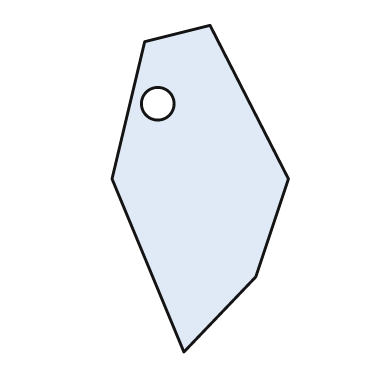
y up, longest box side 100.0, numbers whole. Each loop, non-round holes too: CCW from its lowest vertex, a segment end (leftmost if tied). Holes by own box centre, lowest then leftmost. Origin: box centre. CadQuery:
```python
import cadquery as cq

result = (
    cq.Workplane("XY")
    .moveTo(-5.0, -50.0)
    .lineTo(17.0, -27.0)
    .lineTo(27.0, 3.0)
    .lineTo(3.0, 50.0)
    .lineTo(-17.0, 45.0)
    .lineTo(-27.0, 3.0)
    .close()
    .moveTo(-13.0, 26.0)
    .circle(5.0)
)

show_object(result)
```